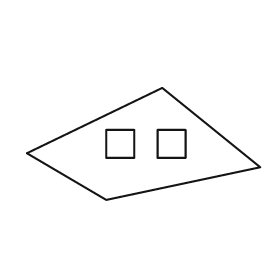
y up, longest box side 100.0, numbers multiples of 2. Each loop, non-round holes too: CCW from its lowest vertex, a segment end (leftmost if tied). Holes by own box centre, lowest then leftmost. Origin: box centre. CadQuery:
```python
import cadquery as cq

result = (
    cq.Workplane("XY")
    .moveTo(-16.0, -24.0)
    .lineTo(50.0, -10.0)
    .lineTo(8.0, 24.0)
    .lineTo(-50.0, -4.0)
    .close()
    .moveTo(-16.0, -6.0)
    .lineTo(-4.0, -6.0)
    .lineTo(-4.0, 6.0)
    .lineTo(-16.0, 6.0)
    .close()
    .moveTo(6.0, -6.0)
    .lineTo(18.0, -6.0)
    .lineTo(18.0, 6.0)
    .lineTo(6.0, 6.0)
    .close()
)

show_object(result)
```